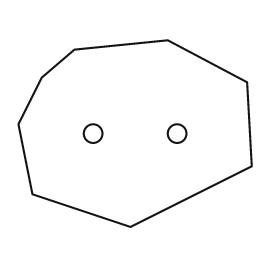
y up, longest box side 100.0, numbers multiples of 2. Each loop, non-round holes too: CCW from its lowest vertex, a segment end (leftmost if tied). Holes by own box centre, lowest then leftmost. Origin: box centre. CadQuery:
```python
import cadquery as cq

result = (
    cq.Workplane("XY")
    .moveTo(-2.0, -40.0)
    .lineTo(50.0, -14.0)
    .lineTo(48.0, 22.0)
    .lineTo(14.0, 40.0)
    .lineTo(-26.0, 36.0)
    .lineTo(-40.0, 24.0)
    .lineTo(-50.0, 4.0)
    .lineTo(-44.0, -26.0)
    .close()
    .moveTo(-18.0, 0.0)
    .circle(4.0)
    .moveTo(18.0, 0.0)
    .circle(4.0)
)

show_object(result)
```